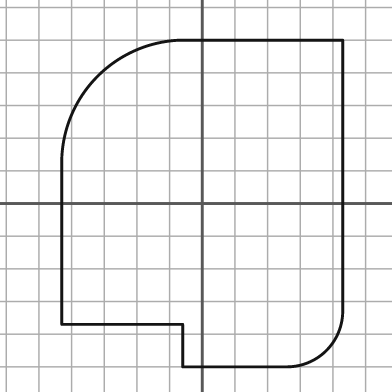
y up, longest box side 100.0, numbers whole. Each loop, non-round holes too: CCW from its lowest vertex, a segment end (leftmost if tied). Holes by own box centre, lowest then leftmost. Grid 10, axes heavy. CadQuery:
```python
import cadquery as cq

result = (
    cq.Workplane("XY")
    .moveTo(-6.0, -50.0)
    .lineTo(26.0, -50.0)
    .threePointArc((38.0, -45.0), (43.0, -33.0))
    .lineTo(43.0, 50.0)
    .lineTo(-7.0, 50.0)
    .threePointArc((-32.0, 39.0), (-43.0, 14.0))
    .lineTo(-43.0, -37.0)
    .lineTo(-6.0, -37.0)
    .close()
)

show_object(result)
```